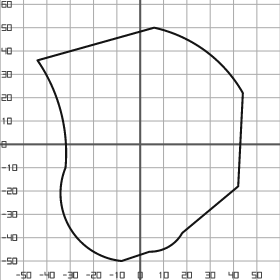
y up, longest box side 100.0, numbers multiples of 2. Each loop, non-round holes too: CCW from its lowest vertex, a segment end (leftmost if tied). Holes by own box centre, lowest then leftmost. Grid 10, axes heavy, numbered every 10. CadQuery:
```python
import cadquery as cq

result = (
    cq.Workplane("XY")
    .moveTo(-8.0, -50.0)
    .lineTo(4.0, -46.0)
    .threePointArc((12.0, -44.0), (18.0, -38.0))
    .lineTo(42.0, -18.0)
    .lineTo(44.0, 22.0)
    .threePointArc((28.0, 40.0), (6.0, 50.0))
    .lineTo(-44.0, 36.0)
    .threePointArc((-34.0, 14.0), (-32.0, -10.0))
    .threePointArc((-30.0, -36.0), (-8.0, -50.0))
    .close()
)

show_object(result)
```